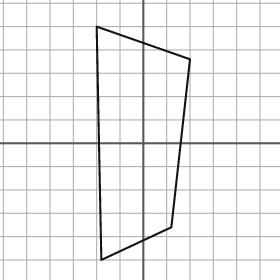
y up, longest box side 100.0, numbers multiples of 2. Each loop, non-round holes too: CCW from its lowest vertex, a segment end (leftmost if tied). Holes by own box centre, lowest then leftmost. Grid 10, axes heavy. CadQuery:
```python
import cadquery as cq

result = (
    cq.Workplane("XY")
    .moveTo(-18.0, -50.0)
    .lineTo(12.0, -36.0)
    .lineTo(20.0, 36.0)
    .lineTo(-20.0, 50.0)
    .close()
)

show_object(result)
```